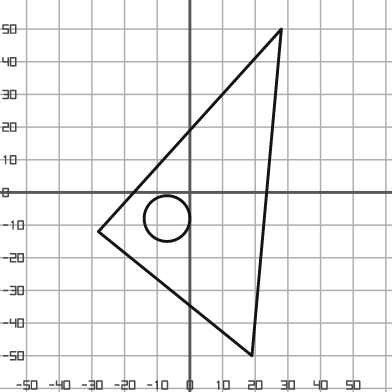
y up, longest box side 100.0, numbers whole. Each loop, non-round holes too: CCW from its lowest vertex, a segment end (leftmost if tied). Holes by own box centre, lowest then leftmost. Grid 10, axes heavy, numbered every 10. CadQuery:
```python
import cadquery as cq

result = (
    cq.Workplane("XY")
    .moveTo(19.0, -50.0)
    .lineTo(28.0, 50.0)
    .lineTo(-28.0, -12.0)
    .close()
    .moveTo(-7.0, -8.0)
    .circle(7.0)
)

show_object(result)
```